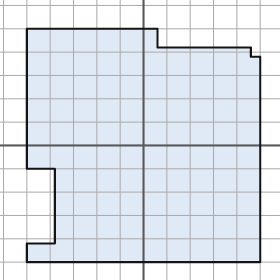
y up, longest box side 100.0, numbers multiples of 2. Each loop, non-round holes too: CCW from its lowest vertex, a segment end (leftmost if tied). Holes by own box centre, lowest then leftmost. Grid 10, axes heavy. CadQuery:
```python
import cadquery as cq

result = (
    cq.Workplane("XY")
    .moveTo(-50.0, -50.0)
    .lineTo(50.0, -50.0)
    .lineTo(50.0, 38.0)
    .lineTo(46.0, 38.0)
    .lineTo(46.0, 42.0)
    .lineTo(6.0, 42.0)
    .lineTo(6.0, 50.0)
    .lineTo(-50.0, 50.0)
    .lineTo(-50.0, -10.0)
    .lineTo(-38.0, -10.0)
    .lineTo(-38.0, -42.0)
    .lineTo(-50.0, -42.0)
    .close()
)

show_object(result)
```